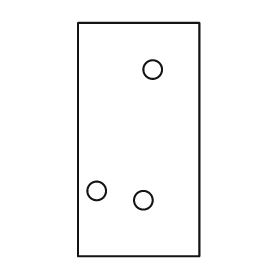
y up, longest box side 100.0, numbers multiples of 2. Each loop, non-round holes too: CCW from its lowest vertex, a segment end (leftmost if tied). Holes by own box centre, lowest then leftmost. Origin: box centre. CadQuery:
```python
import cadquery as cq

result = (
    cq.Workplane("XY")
    .moveTo(-26.0, -50.0)
    .lineTo(26.0, -50.0)
    .lineTo(26.0, 50.0)
    .lineTo(-26.0, 50.0)
    .close()
    .moveTo(2.0, -26.0)
    .circle(4.0)
    .moveTo(-18.0, -22.0)
    .circle(4.0)
    .moveTo(6.0, 30.0)
    .circle(4.0)
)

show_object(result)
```